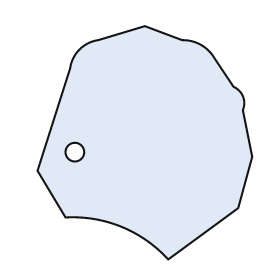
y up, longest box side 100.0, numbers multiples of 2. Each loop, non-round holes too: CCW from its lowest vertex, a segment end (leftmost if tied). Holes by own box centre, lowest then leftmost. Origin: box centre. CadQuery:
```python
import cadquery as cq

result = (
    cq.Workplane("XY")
    .moveTo(10.0, -50.0)
    .lineTo(40.0, -28.0)
    .lineTo(46.0, -6.0)
    .lineTo(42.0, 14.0)
    .threePointArc((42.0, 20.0), (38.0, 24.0))
    .lineTo(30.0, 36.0)
    .threePointArc((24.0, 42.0), (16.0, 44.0))
    .lineTo(0.0, 50.0)
    .lineTo(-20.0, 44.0)
    .threePointArc((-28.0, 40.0), (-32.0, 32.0))
    .lineTo(-46.0, -12.0)
    .lineTo(-34.0, -32.0)
    .threePointArc((-10.0, -36.0), (10.0, -50.0))
    .close()
    .moveTo(-30.0, -4.0)
    .circle(4.0)
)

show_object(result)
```